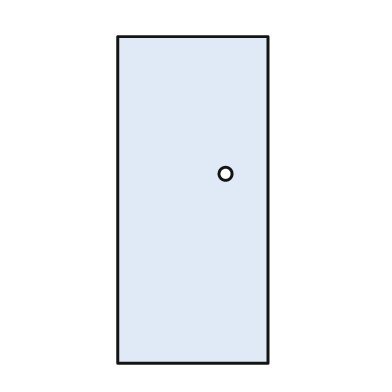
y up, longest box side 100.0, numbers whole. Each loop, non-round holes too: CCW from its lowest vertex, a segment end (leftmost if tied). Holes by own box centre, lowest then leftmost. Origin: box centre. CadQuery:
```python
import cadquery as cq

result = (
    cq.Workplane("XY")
    .moveTo(-23.0, -50.0)
    .lineTo(23.0, -50.0)
    .lineTo(23.0, 50.0)
    .lineTo(-23.0, 50.0)
    .close()
    .moveTo(10.0, 8.0)
    .circle(2.0)
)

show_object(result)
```